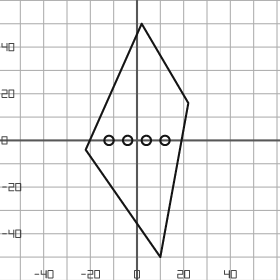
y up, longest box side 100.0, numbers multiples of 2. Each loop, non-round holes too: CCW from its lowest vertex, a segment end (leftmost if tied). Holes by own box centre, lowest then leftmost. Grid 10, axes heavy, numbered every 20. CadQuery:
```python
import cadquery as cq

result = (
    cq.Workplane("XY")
    .moveTo(10.0, -50.0)
    .lineTo(22.0, 16.0)
    .lineTo(2.0, 50.0)
    .lineTo(-22.0, -4.0)
    .close()
    .moveTo(-12.0, 0.0)
    .circle(2.0)
    .moveTo(-4.0, 0.0)
    .circle(2.0)
    .moveTo(4.0, 0.0)
    .circle(2.0)
    .moveTo(12.0, 0.0)
    .circle(2.0)
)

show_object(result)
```